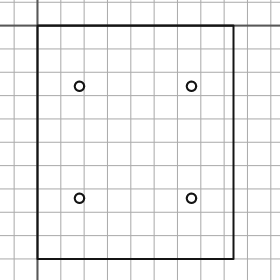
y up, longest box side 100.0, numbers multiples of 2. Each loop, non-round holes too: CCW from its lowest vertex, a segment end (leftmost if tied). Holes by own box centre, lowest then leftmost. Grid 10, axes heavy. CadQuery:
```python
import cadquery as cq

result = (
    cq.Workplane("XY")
    .moveTo(0.0, -100.0)
    .lineTo(84.0, -100.0)
    .lineTo(84.0, 0.0)
    .lineTo(0.0, 0.0)
    .close()
    .moveTo(18.0, -74.0)
    .circle(2.0)
    .moveTo(66.0, -74.0)
    .circle(2.0)
    .moveTo(18.0, -26.0)
    .circle(2.0)
    .moveTo(66.0, -26.0)
    .circle(2.0)
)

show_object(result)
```